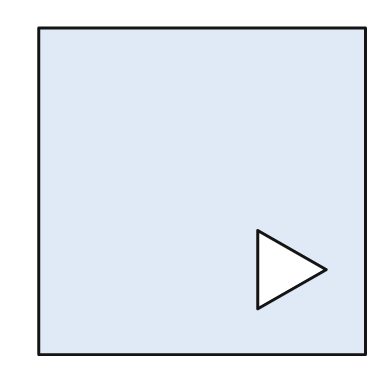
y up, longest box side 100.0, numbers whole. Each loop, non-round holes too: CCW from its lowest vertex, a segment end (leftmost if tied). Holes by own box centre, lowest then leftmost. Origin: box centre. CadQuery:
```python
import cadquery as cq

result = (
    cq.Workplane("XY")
    .moveTo(-50.0, -50.0)
    .lineTo(50.0, -50.0)
    .lineTo(50.0, 50.0)
    .lineTo(-50.0, 50.0)
    .close()
    .moveTo(17.0, -36.0)
    .lineTo(38.0, -24.0)
    .lineTo(17.0, -12.0)
    .close()
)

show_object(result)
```